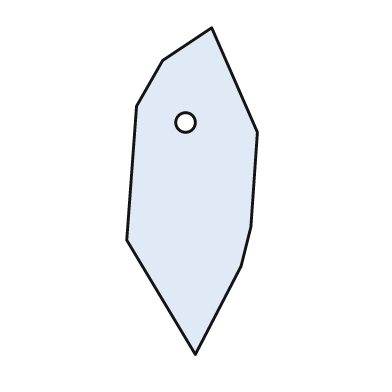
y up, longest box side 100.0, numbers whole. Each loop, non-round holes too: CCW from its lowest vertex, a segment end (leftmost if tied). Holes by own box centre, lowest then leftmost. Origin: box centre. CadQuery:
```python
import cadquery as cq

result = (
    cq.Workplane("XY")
    .moveTo(1.0, -50.0)
    .lineTo(15.0, -23.0)
    .lineTo(18.0, -11.0)
    .lineTo(20.0, 18.0)
    .lineTo(6.0, 50.0)
    .lineTo(-9.0, 40.0)
    .lineTo(-17.0, 26.0)
    .lineTo(-20.0, -15.0)
    .close()
    .moveTo(-2.0, 21.0)
    .circle(3.0)
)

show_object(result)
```